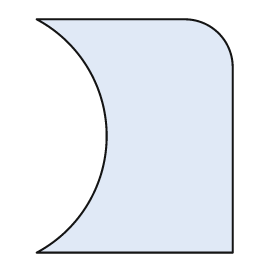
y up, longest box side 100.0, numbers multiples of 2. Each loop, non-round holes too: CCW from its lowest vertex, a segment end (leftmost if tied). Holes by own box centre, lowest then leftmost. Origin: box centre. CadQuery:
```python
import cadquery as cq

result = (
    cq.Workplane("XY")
    .moveTo(-42.0, -50.0)
    .lineTo(42.0, -50.0)
    .lineTo(42.0, 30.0)
    .threePointArc((36.0, 44.0), (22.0, 50.0))
    .lineTo(-42.0, 50.0)
    .threePointArc((-12.0, 0.0), (-42.0, -50.0))
    .close()
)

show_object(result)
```